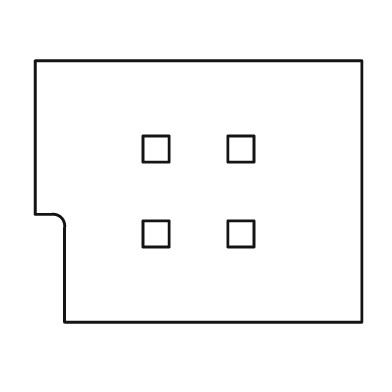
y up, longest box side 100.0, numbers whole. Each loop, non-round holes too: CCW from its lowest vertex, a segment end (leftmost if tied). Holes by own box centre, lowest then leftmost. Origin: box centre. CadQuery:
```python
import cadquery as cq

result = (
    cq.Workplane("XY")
    .moveTo(-41.0, -40.0)
    .lineTo(50.0, -40.0)
    .lineTo(50.0, 40.0)
    .lineTo(-50.0, 40.0)
    .lineTo(-50.0, -7.0)
    .lineTo(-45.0, -7.0)
    .threePointArc((-42.0, -8.0), (-41.0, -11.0))
    .close()
    .moveTo(-17.0, -17.0)
    .lineTo(-9.0, -17.0)
    .lineTo(-9.0, -9.0)
    .lineTo(-17.0, -9.0)
    .close()
    .moveTo(9.0, -17.0)
    .lineTo(17.0, -17.0)
    .lineTo(17.0, -9.0)
    .lineTo(9.0, -9.0)
    .close()
    .moveTo(-17.0, 9.0)
    .lineTo(-9.0, 9.0)
    .lineTo(-9.0, 17.0)
    .lineTo(-17.0, 17.0)
    .close()
    .moveTo(9.0, 9.0)
    .lineTo(17.0, 9.0)
    .lineTo(17.0, 17.0)
    .lineTo(9.0, 17.0)
    .close()
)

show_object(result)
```